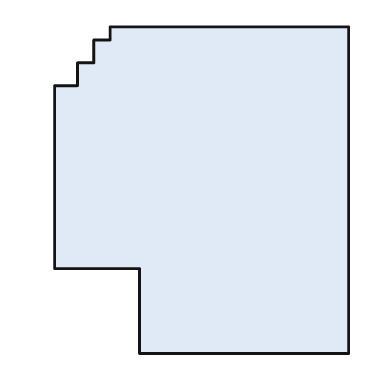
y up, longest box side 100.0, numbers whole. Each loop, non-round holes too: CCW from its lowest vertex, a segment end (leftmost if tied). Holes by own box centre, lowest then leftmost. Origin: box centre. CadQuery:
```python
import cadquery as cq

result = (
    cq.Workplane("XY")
    .moveTo(-19.0, -50.0)
    .lineTo(45.0, -50.0)
    .lineTo(45.0, 50.0)
    .lineTo(-28.0, 50.0)
    .lineTo(-28.0, 46.0)
    .lineTo(-33.0, 46.0)
    .lineTo(-33.0, 39.0)
    .lineTo(-38.0, 39.0)
    .lineTo(-38.0, 32.0)
    .lineTo(-45.0, 32.0)
    .lineTo(-45.0, -24.0)
    .lineTo(-19.0, -24.0)
    .close()
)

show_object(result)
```